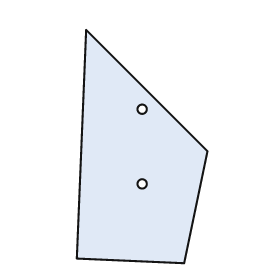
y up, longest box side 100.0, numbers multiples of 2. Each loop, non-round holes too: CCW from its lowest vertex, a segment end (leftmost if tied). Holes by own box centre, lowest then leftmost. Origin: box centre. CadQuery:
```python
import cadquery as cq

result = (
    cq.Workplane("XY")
    .moveTo(18.0, -50.0)
    .lineTo(28.0, -2.0)
    .lineTo(-24.0, 50.0)
    .lineTo(-28.0, -48.0)
    .close()
    .moveTo(0.0, -16.0)
    .circle(2.0)
    .moveTo(0.0, 16.0)
    .circle(2.0)
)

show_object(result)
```